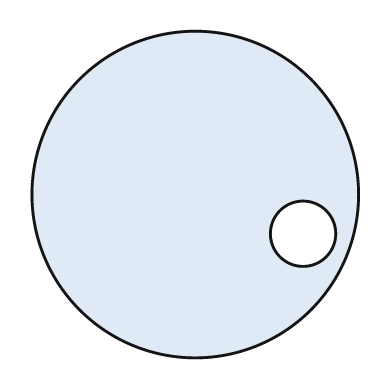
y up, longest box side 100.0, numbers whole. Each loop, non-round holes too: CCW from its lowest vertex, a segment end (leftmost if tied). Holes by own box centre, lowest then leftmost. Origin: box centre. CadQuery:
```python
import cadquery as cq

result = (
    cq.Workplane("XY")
    .moveTo(0.0, 0.0)
    .circle(50.0)
    .moveTo(33.0, -12.0)
    .circle(10.0)
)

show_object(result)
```